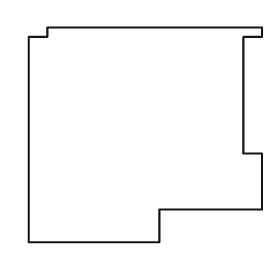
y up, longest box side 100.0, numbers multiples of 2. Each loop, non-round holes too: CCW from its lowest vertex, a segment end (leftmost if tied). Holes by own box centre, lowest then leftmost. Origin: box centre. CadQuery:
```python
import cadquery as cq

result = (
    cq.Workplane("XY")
    .moveTo(-50.0, -46.0)
    .lineTo(6.0, -46.0)
    .lineTo(6.0, -32.0)
    .lineTo(50.0, -32.0)
    .lineTo(50.0, -8.0)
    .lineTo(42.0, -8.0)
    .lineTo(42.0, 42.0)
    .lineTo(50.0, 42.0)
    .lineTo(50.0, 46.0)
    .lineTo(-42.0, 46.0)
    .lineTo(-42.0, 42.0)
    .lineTo(-50.0, 42.0)
    .close()
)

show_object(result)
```